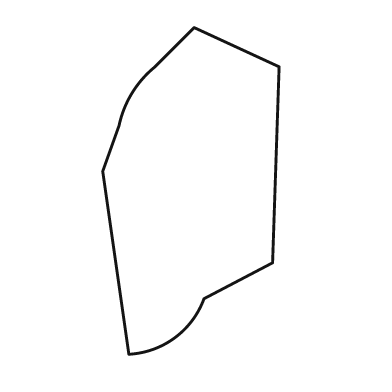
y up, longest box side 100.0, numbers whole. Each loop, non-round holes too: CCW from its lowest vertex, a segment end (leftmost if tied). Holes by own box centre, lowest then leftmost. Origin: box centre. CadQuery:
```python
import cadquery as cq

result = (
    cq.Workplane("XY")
    .moveTo(-19.0, -50.0)
    .threePointArc((-5.0, -45.0), (4.0, -33.0))
    .lineTo(25.0, -22.0)
    .lineTo(27.0, 38.0)
    .lineTo(1.0, 50.0)
    .lineTo(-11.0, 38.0)
    .threePointArc((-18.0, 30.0), (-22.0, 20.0))
    .lineTo(-27.0, 6.0)
    .close()
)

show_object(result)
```